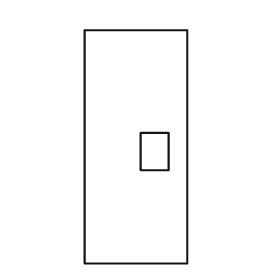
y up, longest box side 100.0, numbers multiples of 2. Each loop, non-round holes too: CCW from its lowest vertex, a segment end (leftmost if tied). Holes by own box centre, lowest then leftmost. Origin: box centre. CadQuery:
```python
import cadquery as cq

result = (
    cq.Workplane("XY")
    .moveTo(-22.0, -50.0)
    .lineTo(22.0, -50.0)
    .lineTo(22.0, 50.0)
    .lineTo(-22.0, 50.0)
    .close()
    .moveTo(2.0, -10.0)
    .lineTo(14.0, -10.0)
    .lineTo(14.0, 6.0)
    .lineTo(2.0, 6.0)
    .close()
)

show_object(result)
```